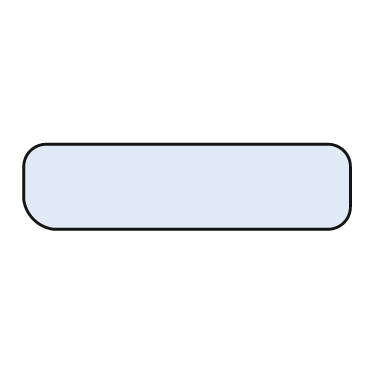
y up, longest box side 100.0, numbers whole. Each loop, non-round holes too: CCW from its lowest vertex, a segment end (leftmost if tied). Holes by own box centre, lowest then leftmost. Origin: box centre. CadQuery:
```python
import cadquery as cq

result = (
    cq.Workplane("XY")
    .moveTo(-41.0, -13.0)
    .lineTo(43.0, -13.0)
    .threePointArc((48.0, -11.0), (50.0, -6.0))
    .lineTo(50.0, 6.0)
    .threePointArc((48.0, 11.0), (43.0, 13.0))
    .lineTo(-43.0, 13.0)
    .threePointArc((-48.0, 11.0), (-50.0, 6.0))
    .lineTo(-50.0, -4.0)
    .threePointArc((-47.0, -10.0), (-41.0, -13.0))
    .close()
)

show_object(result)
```